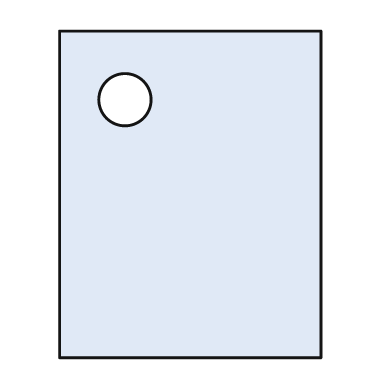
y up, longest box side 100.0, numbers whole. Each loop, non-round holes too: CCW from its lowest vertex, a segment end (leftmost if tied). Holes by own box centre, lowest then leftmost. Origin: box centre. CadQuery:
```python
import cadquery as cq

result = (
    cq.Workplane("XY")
    .moveTo(-40.0, -50.0)
    .lineTo(40.0, -50.0)
    .lineTo(40.0, 50.0)
    .lineTo(-40.0, 50.0)
    .close()
    .moveTo(-20.0, 29.0)
    .circle(8.0)
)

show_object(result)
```